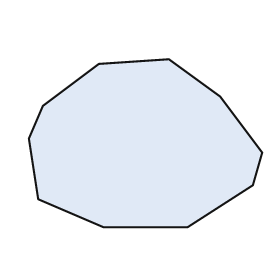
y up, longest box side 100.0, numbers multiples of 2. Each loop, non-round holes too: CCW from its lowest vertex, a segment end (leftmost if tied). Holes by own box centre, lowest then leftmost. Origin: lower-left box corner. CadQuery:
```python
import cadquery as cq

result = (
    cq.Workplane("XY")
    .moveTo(32.0, 0.0)
    .lineTo(68.0, 0.0)
    .lineTo(96.0, 18.0)
    .lineTo(100.0, 32.0)
    .lineTo(82.0, 56.0)
    .lineTo(60.0, 72.0)
    .lineTo(30.0, 70.0)
    .lineTo(6.0, 52.0)
    .lineTo(0.0, 38.0)
    .lineTo(4.0, 12.0)
    .close()
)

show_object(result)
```